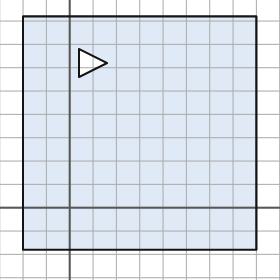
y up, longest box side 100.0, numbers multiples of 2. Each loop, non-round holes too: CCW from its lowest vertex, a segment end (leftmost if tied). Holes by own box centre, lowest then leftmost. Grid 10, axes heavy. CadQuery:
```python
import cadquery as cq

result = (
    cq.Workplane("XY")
    .moveTo(-20.0, -18.0)
    .lineTo(80.0, -18.0)
    .lineTo(80.0, 82.0)
    .lineTo(-20.0, 82.0)
    .close()
    .moveTo(4.0, 56.0)
    .lineTo(16.0, 62.0)
    .lineTo(4.0, 68.0)
    .close()
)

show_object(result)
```